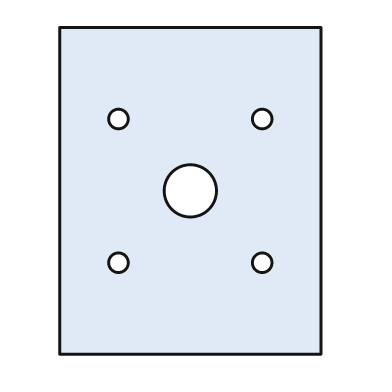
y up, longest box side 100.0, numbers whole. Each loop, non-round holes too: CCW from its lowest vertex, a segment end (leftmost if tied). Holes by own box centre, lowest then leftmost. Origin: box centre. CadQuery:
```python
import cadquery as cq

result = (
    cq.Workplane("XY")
    .moveTo(-40.0, -50.0)
    .lineTo(40.0, -50.0)
    .lineTo(40.0, 50.0)
    .lineTo(-40.0, 50.0)
    .close()
    .moveTo(-22.0, -22.0)
    .circle(3.0)
    .moveTo(22.0, -22.0)
    .circle(3.0)
    .moveTo(0.0, 0.0)
    .circle(8.0)
    .moveTo(-22.0, 22.0)
    .circle(3.0)
    .moveTo(22.0, 22.0)
    .circle(3.0)
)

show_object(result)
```